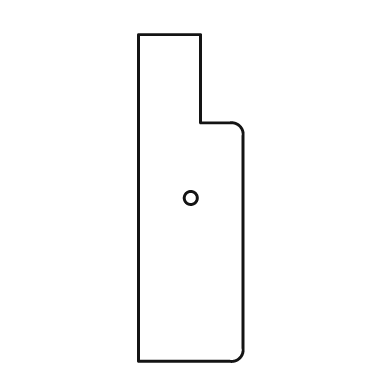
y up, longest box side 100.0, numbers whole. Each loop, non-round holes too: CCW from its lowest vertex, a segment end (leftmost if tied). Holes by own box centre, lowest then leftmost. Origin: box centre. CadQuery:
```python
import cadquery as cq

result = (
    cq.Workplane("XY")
    .moveTo(-16.0, -50.0)
    .lineTo(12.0, -50.0)
    .threePointArc((15.0, -49.0), (16.0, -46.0))
    .lineTo(16.0, 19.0)
    .threePointArc((15.0, 22.0), (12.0, 23.0))
    .lineTo(3.0, 23.0)
    .lineTo(3.0, 50.0)
    .lineTo(-16.0, 50.0)
    .close()
    .moveTo(0.0, 0.0)
    .circle(2.0)
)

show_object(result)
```